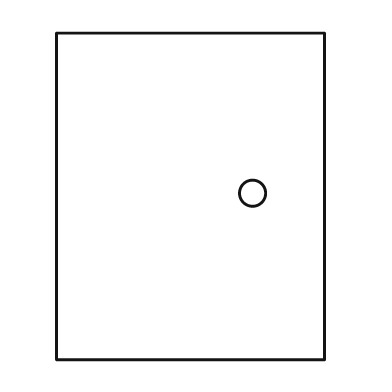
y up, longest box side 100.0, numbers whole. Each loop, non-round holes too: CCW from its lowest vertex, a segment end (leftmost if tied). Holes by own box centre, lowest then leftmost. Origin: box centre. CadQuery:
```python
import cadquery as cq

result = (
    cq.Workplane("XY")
    .moveTo(-41.0, -50.0)
    .lineTo(41.0, -50.0)
    .lineTo(41.0, 50.0)
    .lineTo(-41.0, 50.0)
    .close()
    .moveTo(19.0, 1.0)
    .circle(4.0)
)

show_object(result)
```